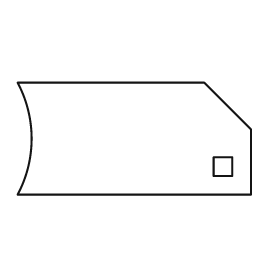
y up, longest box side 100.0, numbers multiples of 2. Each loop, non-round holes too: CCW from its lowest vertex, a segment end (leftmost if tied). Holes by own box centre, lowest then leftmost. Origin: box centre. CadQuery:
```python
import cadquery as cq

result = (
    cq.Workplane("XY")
    .moveTo(-50.0, -24.0)
    .lineTo(50.0, -24.0)
    .lineTo(50.0, 4.0)
    .lineTo(30.0, 24.0)
    .lineTo(-50.0, 24.0)
    .threePointArc((-44.0, 0.0), (-50.0, -24.0))
    .close()
    .moveTo(34.0, -16.0)
    .lineTo(42.0, -16.0)
    .lineTo(42.0, -8.0)
    .lineTo(34.0, -8.0)
    .close()
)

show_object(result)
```